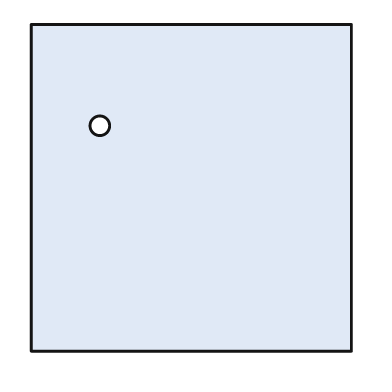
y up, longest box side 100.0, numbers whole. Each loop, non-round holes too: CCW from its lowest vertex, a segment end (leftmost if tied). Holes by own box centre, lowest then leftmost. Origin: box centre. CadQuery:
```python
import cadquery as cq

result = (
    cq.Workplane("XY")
    .moveTo(-49.0, -50.0)
    .lineTo(49.0, -50.0)
    .lineTo(49.0, 50.0)
    .lineTo(-49.0, 50.0)
    .close()
    .moveTo(-28.0, 19.0)
    .circle(3.0)
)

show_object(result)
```